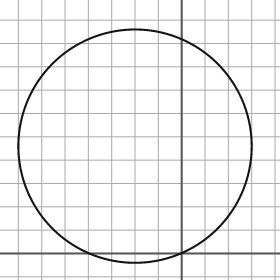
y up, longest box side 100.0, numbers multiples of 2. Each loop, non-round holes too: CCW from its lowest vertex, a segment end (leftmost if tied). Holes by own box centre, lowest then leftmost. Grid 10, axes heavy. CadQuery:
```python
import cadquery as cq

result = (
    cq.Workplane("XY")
    .moveTo(-20.0, 46.0)
    .circle(50.0)
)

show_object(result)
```